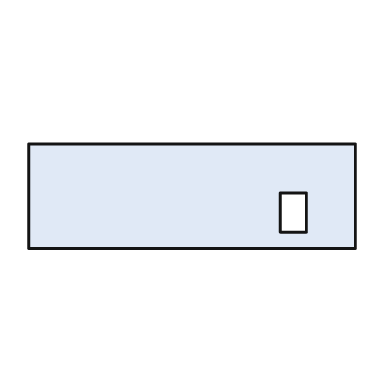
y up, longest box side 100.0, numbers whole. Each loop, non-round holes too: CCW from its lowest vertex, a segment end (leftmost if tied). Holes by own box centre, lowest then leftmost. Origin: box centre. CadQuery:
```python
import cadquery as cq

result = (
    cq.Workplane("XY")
    .moveTo(-50.0, -16.0)
    .lineTo(50.0, -16.0)
    .lineTo(50.0, 16.0)
    .lineTo(-50.0, 16.0)
    .close()
    .moveTo(27.0, -11.0)
    .lineTo(35.0, -11.0)
    .lineTo(35.0, 1.0)
    .lineTo(27.0, 1.0)
    .close()
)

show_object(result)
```